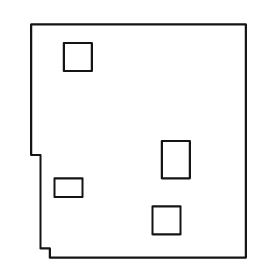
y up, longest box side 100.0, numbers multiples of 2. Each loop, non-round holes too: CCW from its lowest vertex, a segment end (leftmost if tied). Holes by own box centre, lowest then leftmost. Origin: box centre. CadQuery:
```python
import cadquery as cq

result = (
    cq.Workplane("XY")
    .moveTo(-38.0, -50.0)
    .lineTo(46.0, -50.0)
    .lineTo(46.0, 50.0)
    .lineTo(-46.0, 50.0)
    .lineTo(-46.0, -6.0)
    .lineTo(-42.0, -6.0)
    .lineTo(-42.0, -46.0)
    .lineTo(-38.0, -46.0)
    .close()
    .moveTo(6.0, -40.0)
    .lineTo(18.0, -40.0)
    .lineTo(18.0, -28.0)
    .lineTo(6.0, -28.0)
    .close()
    .moveTo(-36.0, -24.0)
    .lineTo(-24.0, -24.0)
    .lineTo(-24.0, -16.0)
    .lineTo(-36.0, -16.0)
    .close()
    .moveTo(10.0, -16.0)
    .lineTo(22.0, -16.0)
    .lineTo(22.0, 0.0)
    .lineTo(10.0, 0.0)
    .close()
    .moveTo(-32.0, 30.0)
    .lineTo(-20.0, 30.0)
    .lineTo(-20.0, 42.0)
    .lineTo(-32.0, 42.0)
    .close()
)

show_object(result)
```